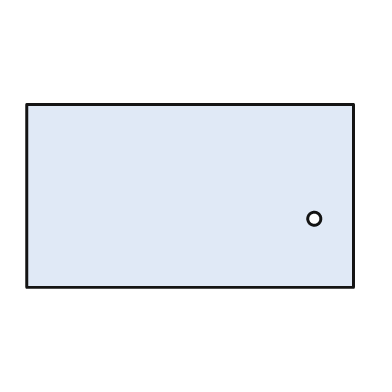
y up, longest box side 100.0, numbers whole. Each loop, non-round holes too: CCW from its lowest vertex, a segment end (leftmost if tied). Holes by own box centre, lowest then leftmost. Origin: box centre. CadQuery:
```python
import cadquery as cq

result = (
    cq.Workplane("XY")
    .moveTo(-50.0, -28.0)
    .lineTo(50.0, -28.0)
    .lineTo(50.0, 28.0)
    .lineTo(-50.0, 28.0)
    .close()
    .moveTo(38.0, -7.0)
    .circle(2.0)
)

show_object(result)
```